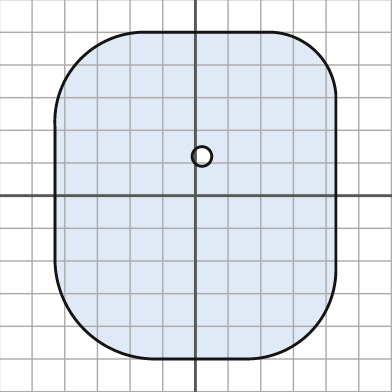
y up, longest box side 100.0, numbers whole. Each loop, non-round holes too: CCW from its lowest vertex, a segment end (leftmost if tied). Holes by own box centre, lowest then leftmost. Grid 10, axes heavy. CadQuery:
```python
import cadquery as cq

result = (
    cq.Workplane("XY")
    .moveTo(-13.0, -50.0)
    .lineTo(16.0, -50.0)
    .threePointArc((35.0, -42.0), (43.0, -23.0))
    .lineTo(43.0, 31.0)
    .threePointArc((37.0, 44.0), (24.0, 50.0))
    .lineTo(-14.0, 50.0)
    .threePointArc((-35.0, 42.0), (-43.0, 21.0))
    .lineTo(-43.0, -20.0)
    .threePointArc((-34.0, -41.0), (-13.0, -50.0))
    .close()
    .moveTo(2.0, 12.0)
    .circle(3.0)
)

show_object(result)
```